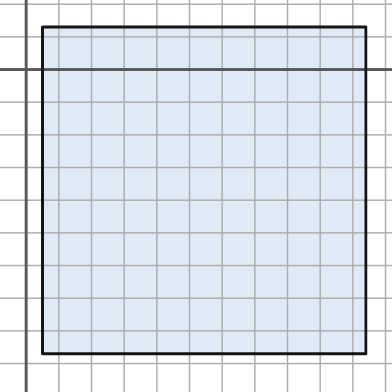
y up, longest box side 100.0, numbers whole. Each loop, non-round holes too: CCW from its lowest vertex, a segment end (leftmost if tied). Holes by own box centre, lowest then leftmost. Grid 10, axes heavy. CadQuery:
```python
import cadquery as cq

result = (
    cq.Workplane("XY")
    .moveTo(5.0, -87.0)
    .lineTo(104.0, -87.0)
    .lineTo(104.0, 13.0)
    .lineTo(5.0, 13.0)
    .close()
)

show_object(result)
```